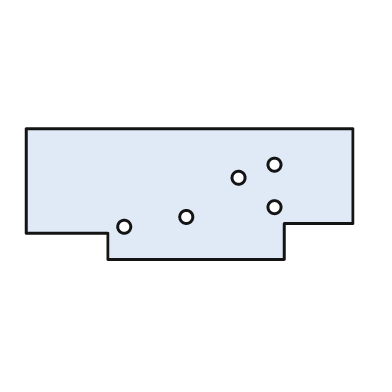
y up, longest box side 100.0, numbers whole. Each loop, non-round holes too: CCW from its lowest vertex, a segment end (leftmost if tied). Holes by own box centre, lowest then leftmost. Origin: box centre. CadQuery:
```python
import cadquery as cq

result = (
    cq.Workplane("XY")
    .moveTo(-25.0, -20.0)
    .lineTo(29.0, -20.0)
    .lineTo(29.0, -9.0)
    .lineTo(50.0, -9.0)
    .lineTo(50.0, 20.0)
    .lineTo(-50.0, 20.0)
    .lineTo(-50.0, -12.0)
    .lineTo(-25.0, -12.0)
    .close()
    .moveTo(-20.0, -10.0)
    .circle(2.0)
    .moveTo(-1.0, -7.0)
    .circle(2.0)
    .moveTo(26.0, -4.0)
    .circle(2.0)
    .moveTo(15.0, 5.0)
    .circle(2.0)
    .moveTo(26.0, 9.0)
    .circle(2.0)
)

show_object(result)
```